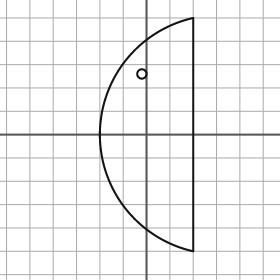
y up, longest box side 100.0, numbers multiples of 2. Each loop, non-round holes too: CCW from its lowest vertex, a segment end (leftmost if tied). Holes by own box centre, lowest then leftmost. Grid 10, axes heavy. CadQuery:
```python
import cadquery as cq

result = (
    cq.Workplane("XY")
    .moveTo(20.0, -50.0)
    .lineTo(20.0, 50.0)
    .threePointArc((-20.0, 0.0), (20.0, -50.0))
    .close()
    .moveTo(-2.0, 26.0)
    .circle(2.0)
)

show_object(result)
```